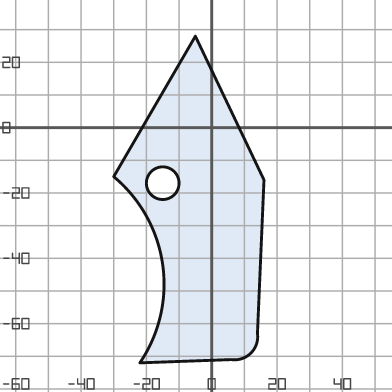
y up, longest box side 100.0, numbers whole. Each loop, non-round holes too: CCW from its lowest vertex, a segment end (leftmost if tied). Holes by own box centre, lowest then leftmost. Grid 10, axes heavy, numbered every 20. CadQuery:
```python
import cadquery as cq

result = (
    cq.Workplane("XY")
    .moveTo(-22.0, -72.0)
    .lineTo(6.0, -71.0)
    .threePointArc((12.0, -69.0), (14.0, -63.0))
    .lineTo(16.0, -16.0)
    .lineTo(-5.0, 28.0)
    .lineTo(-30.0, -15.0)
    .threePointArc((-15.0, -42.0), (-22.0, -72.0))
    .close()
    .moveTo(-15.0, -17.0)
    .circle(5.0)
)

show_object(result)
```